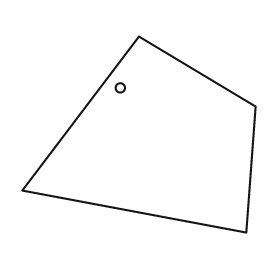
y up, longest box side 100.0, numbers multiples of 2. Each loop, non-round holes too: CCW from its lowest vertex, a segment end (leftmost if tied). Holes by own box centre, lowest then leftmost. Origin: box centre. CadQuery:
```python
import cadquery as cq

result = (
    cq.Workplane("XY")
    .moveTo(46.0, -42.0)
    .lineTo(50.0, 12.0)
    .lineTo(0.0, 42.0)
    .lineTo(-50.0, -24.0)
    .close()
    .moveTo(-8.0, 20.0)
    .circle(2.0)
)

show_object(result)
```